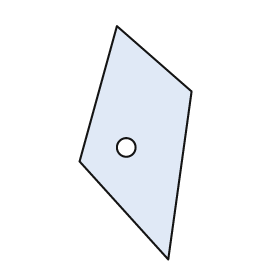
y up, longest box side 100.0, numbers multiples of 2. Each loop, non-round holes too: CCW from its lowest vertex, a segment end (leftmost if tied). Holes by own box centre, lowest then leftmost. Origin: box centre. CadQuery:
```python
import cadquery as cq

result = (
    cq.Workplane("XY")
    .moveTo(14.0, -50.0)
    .lineTo(24.0, 22.0)
    .lineTo(-8.0, 50.0)
    .lineTo(-24.0, -8.0)
    .close()
    .moveTo(-4.0, -2.0)
    .circle(4.0)
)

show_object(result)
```